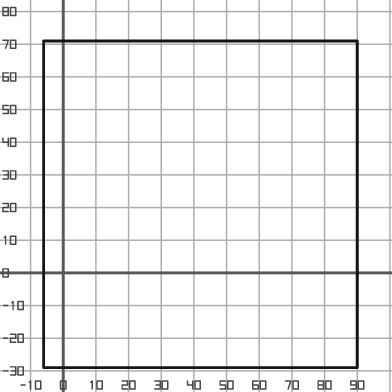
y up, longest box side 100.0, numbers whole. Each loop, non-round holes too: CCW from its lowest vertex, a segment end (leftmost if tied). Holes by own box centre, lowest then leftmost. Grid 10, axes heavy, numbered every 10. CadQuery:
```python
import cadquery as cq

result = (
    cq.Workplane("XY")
    .moveTo(-6.0, -29.0)
    .lineTo(90.0, -29.0)
    .lineTo(90.0, 71.0)
    .lineTo(-6.0, 71.0)
    .close()
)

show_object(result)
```